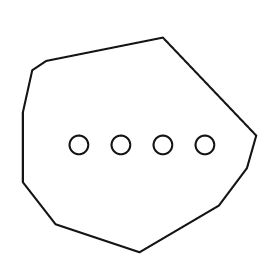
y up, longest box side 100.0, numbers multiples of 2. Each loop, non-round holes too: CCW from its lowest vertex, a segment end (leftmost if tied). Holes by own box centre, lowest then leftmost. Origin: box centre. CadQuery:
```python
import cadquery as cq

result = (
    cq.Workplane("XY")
    .moveTo(0.0, -46.0)
    .lineTo(34.0, -26.0)
    .lineTo(46.0, -10.0)
    .lineTo(50.0, 4.0)
    .lineTo(10.0, 46.0)
    .lineTo(-40.0, 36.0)
    .lineTo(-46.0, 32.0)
    .lineTo(-50.0, 14.0)
    .lineTo(-50.0, -16.0)
    .lineTo(-36.0, -34.0)
    .close()
    .moveTo(-26.0, 0.0)
    .circle(4.0)
    .moveTo(-8.0, 0.0)
    .circle(4.0)
    .moveTo(10.0, 0.0)
    .circle(4.0)
    .moveTo(28.0, 0.0)
    .circle(4.0)
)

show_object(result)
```